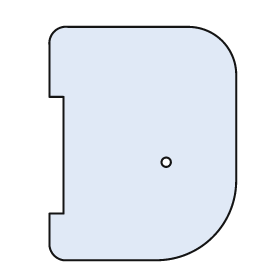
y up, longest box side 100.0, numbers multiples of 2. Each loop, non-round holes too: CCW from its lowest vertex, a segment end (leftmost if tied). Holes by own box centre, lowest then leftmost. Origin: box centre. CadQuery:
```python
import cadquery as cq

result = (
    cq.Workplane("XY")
    .moveTo(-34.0, -50.0)
    .lineTo(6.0, -50.0)
    .threePointArc((30.0, -40.0), (40.0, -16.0))
    .lineTo(40.0, 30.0)
    .threePointArc((34.0, 44.0), (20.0, 50.0))
    .lineTo(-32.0, 50.0)
    .threePointArc((-38.0, 48.0), (-40.0, 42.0))
    .lineTo(-40.0, 20.0)
    .lineTo(-34.0, 20.0)
    .lineTo(-34.0, -30.0)
    .lineTo(-40.0, -30.0)
    .lineTo(-40.0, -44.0)
    .threePointArc((-38.0, -48.0), (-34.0, -50.0))
    .close()
    .moveTo(10.0, -8.0)
    .circle(2.0)
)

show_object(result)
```